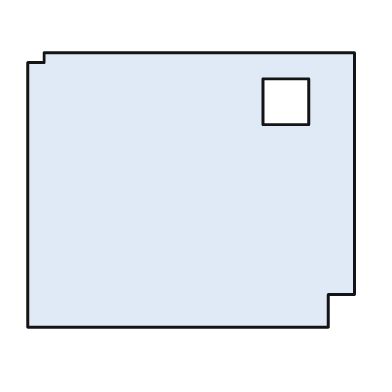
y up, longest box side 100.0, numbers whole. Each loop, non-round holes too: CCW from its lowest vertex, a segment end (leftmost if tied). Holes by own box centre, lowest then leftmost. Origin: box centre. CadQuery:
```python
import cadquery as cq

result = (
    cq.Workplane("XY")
    .moveTo(-50.0, -42.0)
    .lineTo(42.0, -42.0)
    .lineTo(42.0, -32.0)
    .lineTo(50.0, -32.0)
    .lineTo(50.0, 42.0)
    .lineTo(-45.0, 42.0)
    .lineTo(-45.0, 39.0)
    .lineTo(-50.0, 39.0)
    .close()
    .moveTo(22.0, 20.0)
    .lineTo(36.0, 20.0)
    .lineTo(36.0, 34.0)
    .lineTo(22.0, 34.0)
    .close()
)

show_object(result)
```